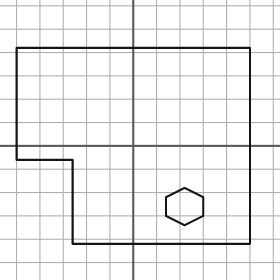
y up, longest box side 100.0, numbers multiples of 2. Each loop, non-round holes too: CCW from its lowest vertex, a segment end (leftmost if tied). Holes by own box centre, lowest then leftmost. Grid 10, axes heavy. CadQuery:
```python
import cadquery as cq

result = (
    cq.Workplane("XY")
    .moveTo(-26.0, -42.0)
    .lineTo(50.0, -42.0)
    .lineTo(50.0, 42.0)
    .lineTo(-50.0, 42.0)
    .lineTo(-50.0, -6.0)
    .lineTo(-26.0, -6.0)
    .close()
    .moveTo(22.0, -34.0)
    .lineTo(30.0, -30.0)
    .lineTo(30.0, -22.0)
    .lineTo(22.0, -18.0)
    .lineTo(14.0, -22.0)
    .lineTo(14.0, -30.0)
    .close()
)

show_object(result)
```